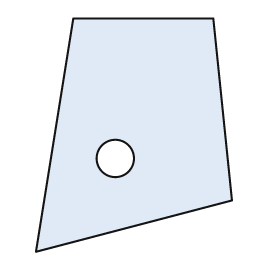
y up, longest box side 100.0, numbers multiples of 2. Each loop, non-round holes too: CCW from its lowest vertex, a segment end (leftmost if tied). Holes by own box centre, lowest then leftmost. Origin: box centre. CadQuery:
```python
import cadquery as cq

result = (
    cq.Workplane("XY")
    .moveTo(-42.0, -50.0)
    .lineTo(42.0, -28.0)
    .lineTo(34.0, 50.0)
    .lineTo(-26.0, 50.0)
    .close()
    .moveTo(-8.0, -10.0)
    .circle(8.0)
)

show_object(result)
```